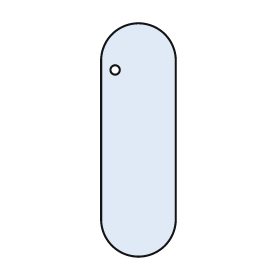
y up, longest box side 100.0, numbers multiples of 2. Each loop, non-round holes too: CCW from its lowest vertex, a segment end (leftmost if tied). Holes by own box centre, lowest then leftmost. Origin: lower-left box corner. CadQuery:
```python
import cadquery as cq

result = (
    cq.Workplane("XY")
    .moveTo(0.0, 16.0)
    .threePointArc((16.0, 0.0), (32.0, 16.0))
    .lineTo(32.0, 84.0)
    .threePointArc((16.0, 100.0), (0.0, 84.0))
    .close()
    .moveTo(6.0, 80.0)
    .circle(2.0)
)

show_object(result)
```